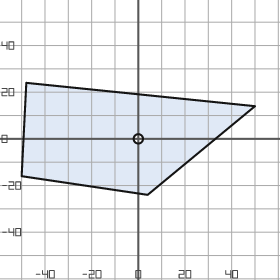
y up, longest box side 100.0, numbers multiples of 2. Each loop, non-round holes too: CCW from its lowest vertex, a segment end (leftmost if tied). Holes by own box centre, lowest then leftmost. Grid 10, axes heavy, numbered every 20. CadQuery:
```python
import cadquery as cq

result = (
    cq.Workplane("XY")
    .moveTo(4.0, -24.0)
    .lineTo(50.0, 14.0)
    .lineTo(-48.0, 24.0)
    .lineTo(-50.0, -16.0)
    .close()
    .moveTo(0.0, 0.0)
    .circle(2.0)
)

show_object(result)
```